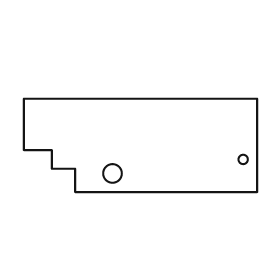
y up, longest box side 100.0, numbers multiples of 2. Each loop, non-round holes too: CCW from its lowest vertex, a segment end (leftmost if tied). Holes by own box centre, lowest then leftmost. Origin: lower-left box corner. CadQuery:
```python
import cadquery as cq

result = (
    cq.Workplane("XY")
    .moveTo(22.0, 0.0)
    .lineTo(100.0, 0.0)
    .lineTo(100.0, 40.0)
    .lineTo(0.0, 40.0)
    .lineTo(0.0, 18.0)
    .lineTo(12.0, 18.0)
    .lineTo(12.0, 10.0)
    .lineTo(22.0, 10.0)
    .close()
    .moveTo(38.0, 8.0)
    .circle(4.0)
    .moveTo(94.0, 14.0)
    .circle(2.0)
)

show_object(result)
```